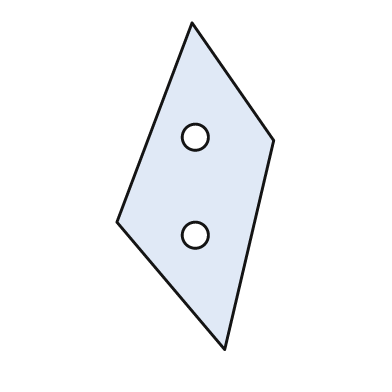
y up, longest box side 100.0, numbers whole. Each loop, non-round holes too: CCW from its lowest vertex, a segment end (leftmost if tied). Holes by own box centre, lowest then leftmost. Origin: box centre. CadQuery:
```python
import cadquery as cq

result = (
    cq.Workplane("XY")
    .moveTo(9.0, -50.0)
    .lineTo(24.0, 14.0)
    .lineTo(-1.0, 50.0)
    .lineTo(-24.0, -11.0)
    .close()
    .moveTo(0.0, -15.0)
    .circle(4.0)
    .moveTo(0.0, 15.0)
    .circle(4.0)
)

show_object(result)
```